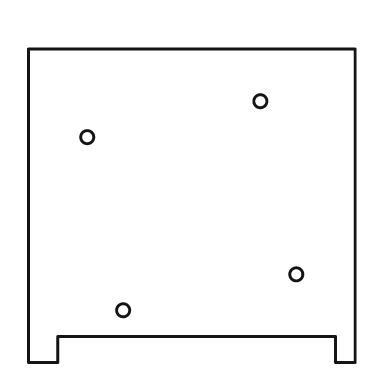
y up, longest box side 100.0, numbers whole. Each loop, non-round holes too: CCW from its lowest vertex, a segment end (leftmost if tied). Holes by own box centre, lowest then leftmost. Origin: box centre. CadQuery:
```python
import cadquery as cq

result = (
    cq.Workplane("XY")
    .moveTo(-50.0, -48.0)
    .lineTo(-41.0, -48.0)
    .lineTo(-41.0, -40.0)
    .lineTo(44.0, -40.0)
    .lineTo(44.0, -48.0)
    .lineTo(50.0, -48.0)
    .lineTo(50.0, 48.0)
    .lineTo(-50.0, 48.0)
    .close()
    .moveTo(-21.0, -32.0)
    .circle(2.0)
    .moveTo(32.0, -21.0)
    .circle(2.0)
    .moveTo(-32.0, 21.0)
    .circle(2.0)
    .moveTo(21.0, 32.0)
    .circle(2.0)
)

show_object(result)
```